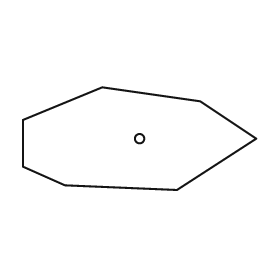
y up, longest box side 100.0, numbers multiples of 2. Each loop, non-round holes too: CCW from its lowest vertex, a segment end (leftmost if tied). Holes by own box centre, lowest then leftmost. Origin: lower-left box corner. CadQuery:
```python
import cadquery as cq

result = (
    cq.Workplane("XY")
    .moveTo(66.0, 0.0)
    .lineTo(100.0, 22.0)
    .lineTo(76.0, 38.0)
    .lineTo(34.0, 44.0)
    .lineTo(0.0, 30.0)
    .lineTo(0.0, 10.0)
    .lineTo(18.0, 2.0)
    .close()
    .moveTo(50.0, 22.0)
    .circle(2.0)
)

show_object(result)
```